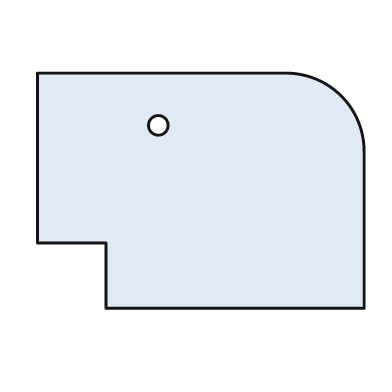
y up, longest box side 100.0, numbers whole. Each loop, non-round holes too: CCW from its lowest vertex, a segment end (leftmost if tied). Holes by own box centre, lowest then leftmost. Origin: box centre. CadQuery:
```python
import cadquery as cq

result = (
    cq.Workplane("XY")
    .moveTo(-29.0, -36.0)
    .lineTo(50.0, -36.0)
    .lineTo(50.0, 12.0)
    .threePointArc((43.0, 29.0), (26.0, 36.0))
    .lineTo(-50.0, 36.0)
    .lineTo(-50.0, -16.0)
    .lineTo(-29.0, -16.0)
    .close()
    .moveTo(-13.0, 20.0)
    .circle(3.0)
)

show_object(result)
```